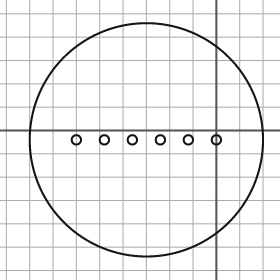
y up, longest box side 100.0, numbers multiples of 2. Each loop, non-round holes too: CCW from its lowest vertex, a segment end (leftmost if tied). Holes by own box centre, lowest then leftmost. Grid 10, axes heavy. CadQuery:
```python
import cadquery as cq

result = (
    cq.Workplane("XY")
    .moveTo(-30.0, -4.0)
    .circle(50.0)
    .moveTo(-60.0, -4.0)
    .circle(2.0)
    .moveTo(-48.0, -4.0)
    .circle(2.0)
    .moveTo(-36.0, -4.0)
    .circle(2.0)
    .moveTo(-24.0, -4.0)
    .circle(2.0)
    .moveTo(-12.0, -4.0)
    .circle(2.0)
    .moveTo(0.0, -4.0)
    .circle(2.0)
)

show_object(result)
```